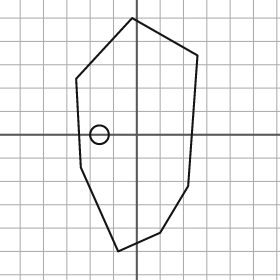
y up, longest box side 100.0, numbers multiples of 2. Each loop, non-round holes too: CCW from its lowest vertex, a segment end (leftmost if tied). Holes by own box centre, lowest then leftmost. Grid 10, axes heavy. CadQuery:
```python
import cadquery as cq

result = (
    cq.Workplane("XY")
    .moveTo(-8.0, -50.0)
    .lineTo(10.0, -42.0)
    .lineTo(22.0, -22.0)
    .lineTo(26.0, 34.0)
    .lineTo(-2.0, 50.0)
    .lineTo(-26.0, 24.0)
    .lineTo(-24.0, -14.0)
    .close()
    .moveTo(-16.0, 0.0)
    .circle(4.0)
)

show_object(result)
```